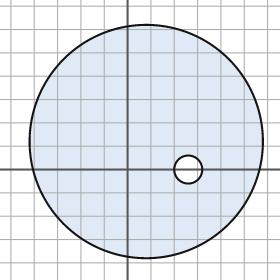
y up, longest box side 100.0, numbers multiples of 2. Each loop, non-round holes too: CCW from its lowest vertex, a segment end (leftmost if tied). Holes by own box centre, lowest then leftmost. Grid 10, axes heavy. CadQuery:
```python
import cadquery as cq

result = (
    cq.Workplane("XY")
    .moveTo(8.0, 12.0)
    .circle(50.0)
    .moveTo(26.0, 0.0)
    .circle(6.0)
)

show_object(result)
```